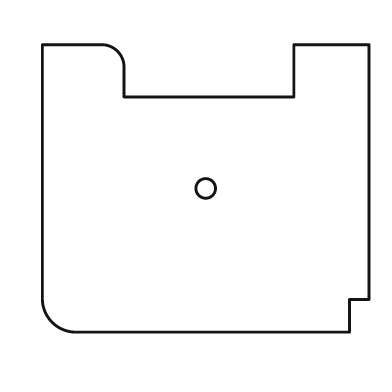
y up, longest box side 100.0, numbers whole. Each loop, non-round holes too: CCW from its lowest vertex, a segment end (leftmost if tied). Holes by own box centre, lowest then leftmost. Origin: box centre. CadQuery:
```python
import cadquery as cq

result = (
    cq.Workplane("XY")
    .moveTo(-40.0, -44.0)
    .lineTo(44.0, -44.0)
    .lineTo(44.0, -34.0)
    .lineTo(50.0, -34.0)
    .lineTo(50.0, 44.0)
    .lineTo(27.0, 44.0)
    .lineTo(27.0, 28.0)
    .lineTo(-25.0, 28.0)
    .lineTo(-25.0, 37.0)
    .threePointArc((-27.0, 42.0), (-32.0, 44.0))
    .lineTo(-50.0, 44.0)
    .lineTo(-50.0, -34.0)
    .threePointArc((-47.0, -41.0), (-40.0, -44.0))
    .close()
    .moveTo(0.0, 0.0)
    .circle(3.0)
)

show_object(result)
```